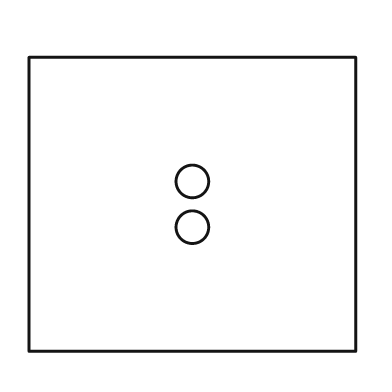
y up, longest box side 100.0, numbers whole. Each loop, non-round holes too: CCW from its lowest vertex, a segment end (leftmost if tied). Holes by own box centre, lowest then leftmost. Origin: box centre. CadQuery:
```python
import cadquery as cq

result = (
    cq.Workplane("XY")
    .moveTo(-50.0, -45.0)
    .lineTo(50.0, -45.0)
    .lineTo(50.0, 45.0)
    .lineTo(-50.0, 45.0)
    .close()
    .moveTo(0.0, -7.0)
    .circle(5.0)
    .moveTo(0.0, 7.0)
    .circle(5.0)
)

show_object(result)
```